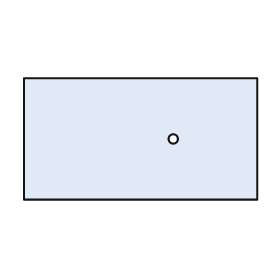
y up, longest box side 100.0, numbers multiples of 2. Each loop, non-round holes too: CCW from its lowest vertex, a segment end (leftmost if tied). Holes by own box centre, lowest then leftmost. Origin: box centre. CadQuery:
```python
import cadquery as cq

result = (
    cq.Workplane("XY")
    .moveTo(-50.0, -26.0)
    .lineTo(50.0, -26.0)
    .lineTo(50.0, 26.0)
    .lineTo(-50.0, 26.0)
    .close()
    .moveTo(14.0, 0.0)
    .circle(2.0)
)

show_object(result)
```